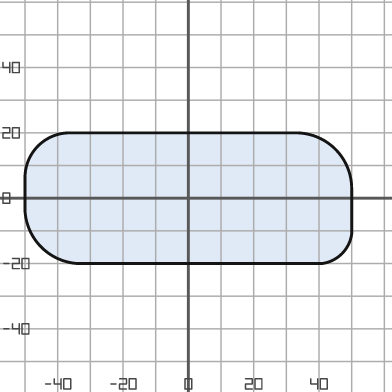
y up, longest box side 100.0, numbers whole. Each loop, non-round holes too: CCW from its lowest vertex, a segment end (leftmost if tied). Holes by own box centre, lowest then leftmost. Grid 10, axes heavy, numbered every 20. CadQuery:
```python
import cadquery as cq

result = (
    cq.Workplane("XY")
    .moveTo(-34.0, -20.0)
    .lineTo(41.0, -20.0)
    .threePointArc((47.0, -17.0), (50.0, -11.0))
    .lineTo(50.0, 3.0)
    .threePointArc((45.0, 15.0), (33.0, 20.0))
    .lineTo(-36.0, 20.0)
    .threePointArc((-46.0, 16.0), (-50.0, 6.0))
    .lineTo(-50.0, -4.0)
    .threePointArc((-45.0, -15.0), (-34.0, -20.0))
    .close()
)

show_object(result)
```